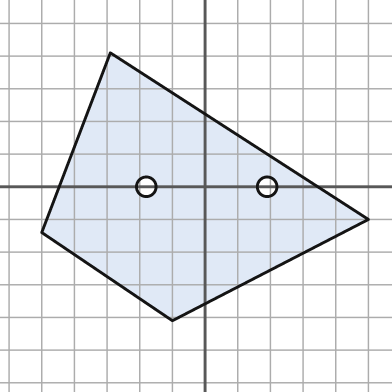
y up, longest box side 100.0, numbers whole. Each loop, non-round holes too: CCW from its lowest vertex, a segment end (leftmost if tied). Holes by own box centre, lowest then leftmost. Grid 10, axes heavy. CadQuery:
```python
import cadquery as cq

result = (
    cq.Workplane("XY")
    .moveTo(-10.0, -41.0)
    .lineTo(50.0, -10.0)
    .lineTo(-29.0, 41.0)
    .lineTo(-50.0, -14.0)
    .close()
    .moveTo(-18.0, 0.0)
    .circle(3.0)
    .moveTo(19.0, 0.0)
    .circle(3.0)
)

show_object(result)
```